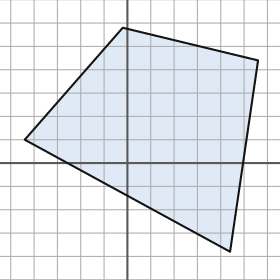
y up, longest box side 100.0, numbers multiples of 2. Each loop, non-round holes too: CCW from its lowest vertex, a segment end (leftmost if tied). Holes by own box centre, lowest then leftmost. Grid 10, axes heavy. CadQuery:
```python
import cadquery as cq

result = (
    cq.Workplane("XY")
    .moveTo(44.0, -38.0)
    .lineTo(56.0, 44.0)
    .lineTo(-2.0, 58.0)
    .lineTo(-44.0, 10.0)
    .close()
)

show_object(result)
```